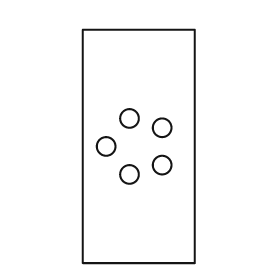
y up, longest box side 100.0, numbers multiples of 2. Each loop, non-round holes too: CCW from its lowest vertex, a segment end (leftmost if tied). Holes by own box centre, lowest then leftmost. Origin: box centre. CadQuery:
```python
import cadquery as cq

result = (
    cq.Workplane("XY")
    .moveTo(-24.0, -50.0)
    .lineTo(24.0, -50.0)
    .lineTo(24.0, 50.0)
    .lineTo(-24.0, 50.0)
    .close()
    .moveTo(-4.0, -12.0)
    .circle(4.0)
    .moveTo(10.0, -8.0)
    .circle(4.0)
    .moveTo(-14.0, 0.0)
    .circle(4.0)
    .moveTo(10.0, 8.0)
    .circle(4.0)
    .moveTo(-4.0, 12.0)
    .circle(4.0)
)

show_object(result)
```